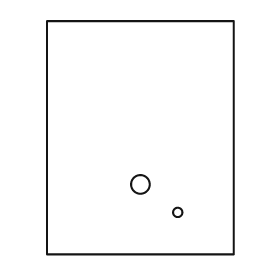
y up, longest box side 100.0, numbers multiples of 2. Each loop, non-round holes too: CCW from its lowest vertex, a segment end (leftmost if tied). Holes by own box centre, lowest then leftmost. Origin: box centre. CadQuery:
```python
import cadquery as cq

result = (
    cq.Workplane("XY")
    .moveTo(-40.0, -50.0)
    .lineTo(40.0, -50.0)
    .lineTo(40.0, 50.0)
    .lineTo(-40.0, 50.0)
    .close()
    .moveTo(16.0, -32.0)
    .circle(2.0)
    .moveTo(0.0, -20.0)
    .circle(4.0)
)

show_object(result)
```